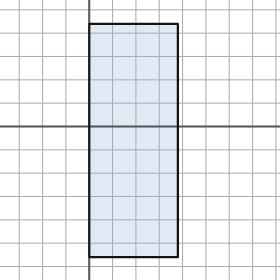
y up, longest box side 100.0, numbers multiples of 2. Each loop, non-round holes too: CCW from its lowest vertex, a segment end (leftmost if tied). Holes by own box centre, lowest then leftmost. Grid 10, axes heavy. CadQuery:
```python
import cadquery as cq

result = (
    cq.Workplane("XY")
    .moveTo(0.0, -56.0)
    .lineTo(38.0, -56.0)
    .lineTo(38.0, 44.0)
    .lineTo(0.0, 44.0)
    .close()
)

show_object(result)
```